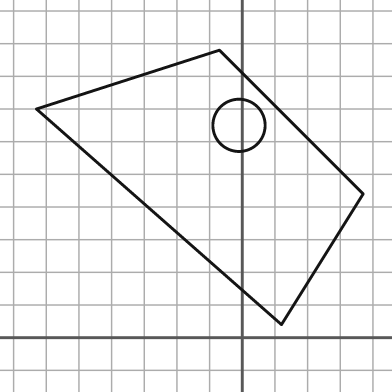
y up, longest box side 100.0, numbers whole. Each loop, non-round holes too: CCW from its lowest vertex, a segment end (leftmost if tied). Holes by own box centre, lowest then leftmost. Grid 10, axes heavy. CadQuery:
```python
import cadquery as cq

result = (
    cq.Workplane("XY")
    .moveTo(12.0, 4.0)
    .lineTo(37.0, 44.0)
    .lineTo(-7.0, 88.0)
    .lineTo(-63.0, 70.0)
    .close()
    .moveTo(-1.0, 65.0)
    .circle(8.0)
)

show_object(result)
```